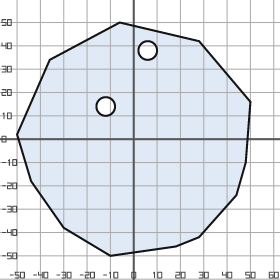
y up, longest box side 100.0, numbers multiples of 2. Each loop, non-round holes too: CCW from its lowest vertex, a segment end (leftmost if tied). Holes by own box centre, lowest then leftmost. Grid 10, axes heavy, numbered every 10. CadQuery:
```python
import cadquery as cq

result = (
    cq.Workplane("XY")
    .moveTo(-10.0, -50.0)
    .lineTo(18.0, -46.0)
    .lineTo(28.0, -42.0)
    .lineTo(44.0, -24.0)
    .lineTo(48.0, -10.0)
    .lineTo(50.0, 16.0)
    .lineTo(28.0, 42.0)
    .lineTo(-6.0, 50.0)
    .lineTo(-36.0, 34.0)
    .lineTo(-50.0, 2.0)
    .lineTo(-44.0, -18.0)
    .lineTo(-30.0, -38.0)
    .close()
    .moveTo(-12.0, 14.0)
    .circle(4.0)
    .moveTo(6.0, 38.0)
    .circle(4.0)
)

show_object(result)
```